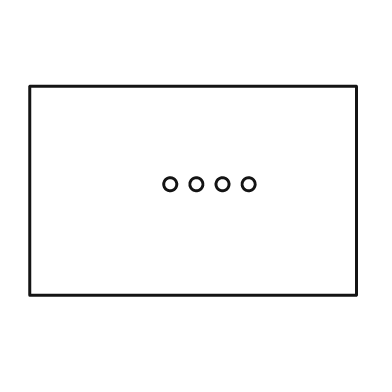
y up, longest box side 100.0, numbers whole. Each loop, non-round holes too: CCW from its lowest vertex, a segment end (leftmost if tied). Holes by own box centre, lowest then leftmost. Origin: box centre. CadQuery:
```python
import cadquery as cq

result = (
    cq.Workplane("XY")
    .moveTo(-50.0, -32.0)
    .lineTo(50.0, -32.0)
    .lineTo(50.0, 32.0)
    .lineTo(-50.0, 32.0)
    .close()
    .moveTo(-7.0, 2.0)
    .circle(2.0)
    .moveTo(1.0, 2.0)
    .circle(2.0)
    .moveTo(9.0, 2.0)
    .circle(2.0)
    .moveTo(17.0, 2.0)
    .circle(2.0)
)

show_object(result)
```